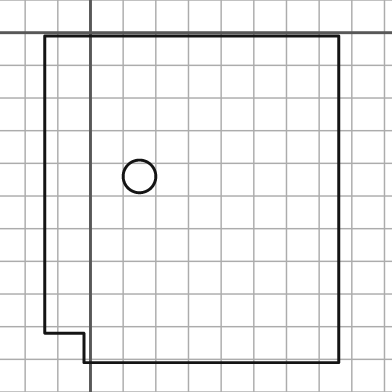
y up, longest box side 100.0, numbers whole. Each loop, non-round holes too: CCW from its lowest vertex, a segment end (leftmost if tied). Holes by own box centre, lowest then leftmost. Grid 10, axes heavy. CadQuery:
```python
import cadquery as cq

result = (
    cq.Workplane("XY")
    .moveTo(-2.0, -101.0)
    .lineTo(76.0, -101.0)
    .lineTo(76.0, -1.0)
    .lineTo(-14.0, -1.0)
    .lineTo(-14.0, -92.0)
    .lineTo(-2.0, -92.0)
    .close()
    .moveTo(15.0, -44.0)
    .circle(5.0)
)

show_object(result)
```